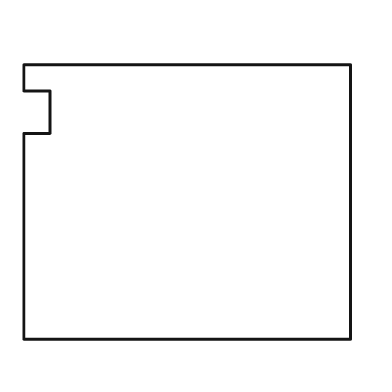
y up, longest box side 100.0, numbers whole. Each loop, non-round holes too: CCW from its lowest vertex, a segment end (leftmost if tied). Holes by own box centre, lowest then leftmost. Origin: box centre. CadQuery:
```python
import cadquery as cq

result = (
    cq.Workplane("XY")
    .moveTo(-50.0, -42.0)
    .lineTo(50.0, -42.0)
    .lineTo(50.0, 42.0)
    .lineTo(-50.0, 42.0)
    .lineTo(-50.0, 34.0)
    .lineTo(-42.0, 34.0)
    .lineTo(-42.0, 21.0)
    .lineTo(-50.0, 21.0)
    .close()
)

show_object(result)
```